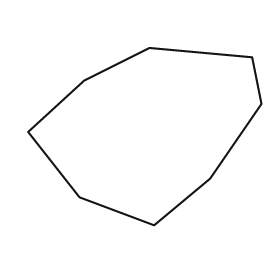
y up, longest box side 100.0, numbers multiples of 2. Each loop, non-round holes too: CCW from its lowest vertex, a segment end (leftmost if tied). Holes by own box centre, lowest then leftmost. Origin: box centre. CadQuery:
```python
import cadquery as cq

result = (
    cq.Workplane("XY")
    .moveTo(4.0, -38.0)
    .lineTo(28.0, -18.0)
    .lineTo(50.0, 14.0)
    .lineTo(46.0, 34.0)
    .lineTo(2.0, 38.0)
    .lineTo(-26.0, 24.0)
    .lineTo(-50.0, 2.0)
    .lineTo(-28.0, -26.0)
    .close()
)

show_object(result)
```